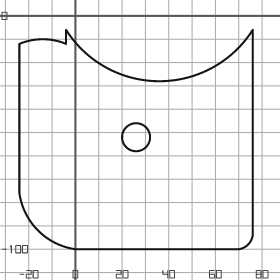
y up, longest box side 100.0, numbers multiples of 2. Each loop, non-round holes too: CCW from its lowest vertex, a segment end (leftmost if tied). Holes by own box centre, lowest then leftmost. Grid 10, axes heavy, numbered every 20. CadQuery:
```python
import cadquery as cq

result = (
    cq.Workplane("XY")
    .moveTo(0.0, -100.0)
    .lineTo(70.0, -100.0)
    .threePointArc((74.0, -98.0), (76.0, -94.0))
    .lineTo(76.0, -6.0)
    .threePointArc((36.0, -28.0), (-4.0, -6.0))
    .lineTo(-4.0, -12.0)
    .threePointArc((-14.0, -10.0), (-24.0, -12.0))
    .lineTo(-24.0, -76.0)
    .threePointArc((-16.0, -92.0), (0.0, -100.0))
    .close()
    .moveTo(26.0, -52.0)
    .circle(6.0)
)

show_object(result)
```